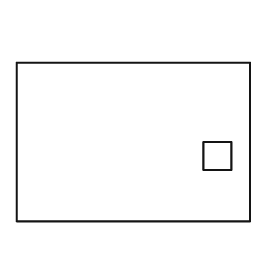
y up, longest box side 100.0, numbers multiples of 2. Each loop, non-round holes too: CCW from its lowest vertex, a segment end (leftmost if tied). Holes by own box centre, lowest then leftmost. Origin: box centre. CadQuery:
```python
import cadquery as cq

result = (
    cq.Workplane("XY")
    .moveTo(-50.0, -34.0)
    .lineTo(50.0, -34.0)
    .lineTo(50.0, 34.0)
    .lineTo(-50.0, 34.0)
    .close()
    .moveTo(30.0, -12.0)
    .lineTo(42.0, -12.0)
    .lineTo(42.0, 0.0)
    .lineTo(30.0, 0.0)
    .close()
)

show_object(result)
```